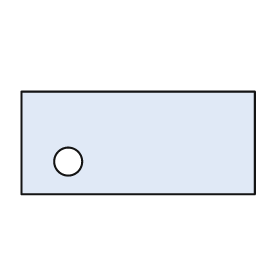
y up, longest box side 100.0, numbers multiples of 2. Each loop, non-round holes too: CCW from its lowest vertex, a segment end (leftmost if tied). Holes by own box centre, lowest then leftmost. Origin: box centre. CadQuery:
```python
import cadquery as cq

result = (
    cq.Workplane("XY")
    .moveTo(-50.0, -22.0)
    .lineTo(50.0, -22.0)
    .lineTo(50.0, 22.0)
    .lineTo(-50.0, 22.0)
    .close()
    .moveTo(-30.0, -8.0)
    .circle(6.0)
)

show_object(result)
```